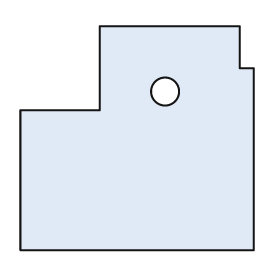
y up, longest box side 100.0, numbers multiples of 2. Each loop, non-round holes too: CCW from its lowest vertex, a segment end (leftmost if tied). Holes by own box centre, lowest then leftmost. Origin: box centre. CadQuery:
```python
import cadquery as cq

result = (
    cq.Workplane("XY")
    .moveTo(-50.0, -48.0)
    .lineTo(50.0, -48.0)
    .lineTo(50.0, 30.0)
    .lineTo(44.0, 30.0)
    .lineTo(44.0, 48.0)
    .lineTo(-16.0, 48.0)
    .lineTo(-16.0, 12.0)
    .lineTo(-50.0, 12.0)
    .close()
    .moveTo(12.0, 20.0)
    .circle(6.0)
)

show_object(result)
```